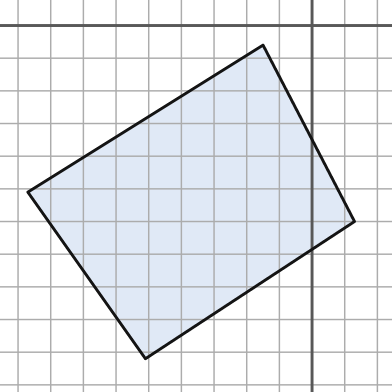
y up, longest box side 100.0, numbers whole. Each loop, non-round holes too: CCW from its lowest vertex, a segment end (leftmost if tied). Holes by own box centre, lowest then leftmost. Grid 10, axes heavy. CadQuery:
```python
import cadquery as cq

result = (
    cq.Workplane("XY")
    .moveTo(-51.0, -102.0)
    .lineTo(13.0, -60.0)
    .lineTo(-15.0, -6.0)
    .lineTo(-87.0, -51.0)
    .close()
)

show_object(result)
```